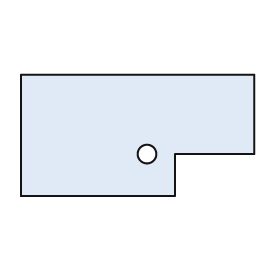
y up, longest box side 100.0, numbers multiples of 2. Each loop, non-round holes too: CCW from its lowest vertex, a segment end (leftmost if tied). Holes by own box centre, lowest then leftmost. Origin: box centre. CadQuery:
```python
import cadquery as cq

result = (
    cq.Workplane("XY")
    .moveTo(-50.0, -26.0)
    .lineTo(16.0, -26.0)
    .lineTo(16.0, -8.0)
    .lineTo(50.0, -8.0)
    .lineTo(50.0, 26.0)
    .lineTo(-50.0, 26.0)
    .close()
    .moveTo(4.0, -8.0)
    .circle(4.0)
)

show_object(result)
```